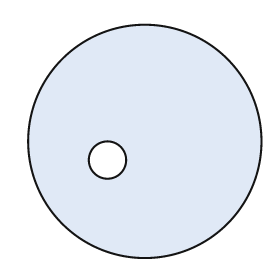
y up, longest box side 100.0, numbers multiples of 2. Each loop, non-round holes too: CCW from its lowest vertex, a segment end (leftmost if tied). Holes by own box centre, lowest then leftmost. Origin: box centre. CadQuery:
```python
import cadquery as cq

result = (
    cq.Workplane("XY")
    .moveTo(0.0, 0.0)
    .circle(50.0)
    .moveTo(-16.0, -8.0)
    .circle(8.0)
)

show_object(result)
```